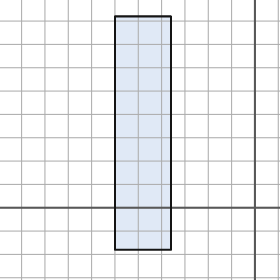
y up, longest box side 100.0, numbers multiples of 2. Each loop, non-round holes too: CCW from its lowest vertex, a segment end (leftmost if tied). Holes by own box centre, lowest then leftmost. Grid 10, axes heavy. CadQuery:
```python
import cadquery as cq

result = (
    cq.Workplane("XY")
    .moveTo(-60.0, -18.0)
    .lineTo(-36.0, -18.0)
    .lineTo(-36.0, 82.0)
    .lineTo(-60.0, 82.0)
    .close()
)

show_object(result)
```